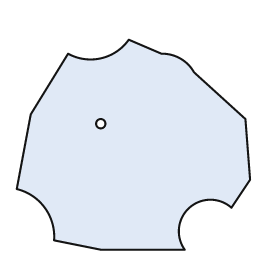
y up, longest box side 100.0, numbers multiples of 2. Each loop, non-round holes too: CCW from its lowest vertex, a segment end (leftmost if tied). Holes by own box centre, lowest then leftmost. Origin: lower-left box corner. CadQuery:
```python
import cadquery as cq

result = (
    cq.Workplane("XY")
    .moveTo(36.0, 0.0)
    .lineTo(72.0, 0.0)
    .threePointArc((74.0, 18.0), (92.0, 18.0))
    .lineTo(100.0, 30.0)
    .lineTo(98.0, 56.0)
    .lineTo(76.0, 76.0)
    .threePointArc((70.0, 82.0), (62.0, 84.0))
    .lineTo(48.0, 90.0)
    .threePointArc((36.0, 82.0), (22.0, 84.0))
    .lineTo(6.0, 58.0)
    .lineTo(0.0, 26.0)
    .threePointArc((12.0, 18.0), (16.0, 4.0))
    .close()
    .moveTo(36.0, 54.0)
    .circle(2.0)
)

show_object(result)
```